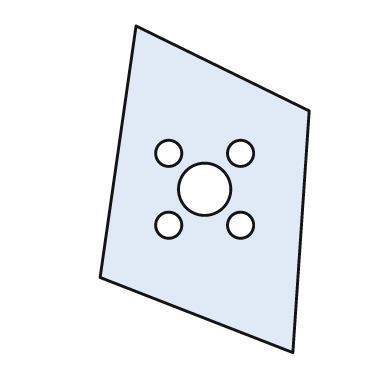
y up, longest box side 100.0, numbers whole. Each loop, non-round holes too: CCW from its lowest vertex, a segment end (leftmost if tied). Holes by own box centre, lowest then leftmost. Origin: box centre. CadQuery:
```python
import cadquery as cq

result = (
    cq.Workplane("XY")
    .moveTo(27.0, -50.0)
    .lineTo(32.0, 24.0)
    .lineTo(-21.0, 50.0)
    .lineTo(-32.0, -27.0)
    .close()
    .moveTo(-11.0, -11.0)
    .circle(4.0)
    .moveTo(11.0, -11.0)
    .circle(4.0)
    .moveTo(0.0, 0.0)
    .circle(8.0)
    .moveTo(-11.0, 11.0)
    .circle(4.0)
    .moveTo(11.0, 11.0)
    .circle(4.0)
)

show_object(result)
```